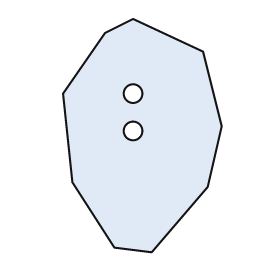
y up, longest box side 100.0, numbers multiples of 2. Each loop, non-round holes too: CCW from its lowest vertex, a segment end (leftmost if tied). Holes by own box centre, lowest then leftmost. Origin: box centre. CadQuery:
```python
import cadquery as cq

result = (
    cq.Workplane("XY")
    .moveTo(4.0, -50.0)
    .lineTo(28.0, -22.0)
    .lineTo(34.0, 4.0)
    .lineTo(26.0, 36.0)
    .lineTo(-4.0, 50.0)
    .lineTo(-16.0, 44.0)
    .lineTo(-34.0, 18.0)
    .lineTo(-30.0, -20.0)
    .lineTo(-12.0, -48.0)
    .close()
    .moveTo(-4.0, 2.0)
    .circle(4.0)
    .moveTo(-4.0, 18.0)
    .circle(4.0)
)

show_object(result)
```